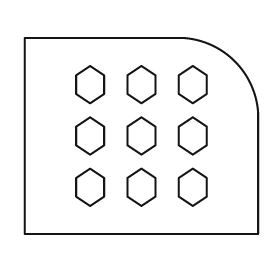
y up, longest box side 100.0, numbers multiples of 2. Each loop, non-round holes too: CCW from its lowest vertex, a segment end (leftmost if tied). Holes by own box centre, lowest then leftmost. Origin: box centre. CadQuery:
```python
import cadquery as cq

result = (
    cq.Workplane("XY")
    .moveTo(-50.0, -42.0)
    .lineTo(50.0, -42.0)
    .lineTo(50.0, 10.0)
    .threePointArc((40.0, 32.0), (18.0, 42.0))
    .lineTo(-50.0, 42.0)
    .close()
    .moveTo(-22.0, -30.0)
    .lineTo(-16.0, -26.0)
    .lineTo(-16.0, -18.0)
    .lineTo(-22.0, -14.0)
    .lineTo(-28.0, -18.0)
    .lineTo(-28.0, -26.0)
    .close()
    .moveTo(0.0, -30.0)
    .lineTo(6.0, -26.0)
    .lineTo(6.0, -18.0)
    .lineTo(0.0, -14.0)
    .lineTo(-6.0, -18.0)
    .lineTo(-6.0, -26.0)
    .close()
    .moveTo(22.0, -30.0)
    .lineTo(28.0, -26.0)
    .lineTo(28.0, -18.0)
    .lineTo(22.0, -14.0)
    .lineTo(16.0, -18.0)
    .lineTo(16.0, -26.0)
    .close()
    .moveTo(-22.0, -8.0)
    .lineTo(-16.0, -4.0)
    .lineTo(-16.0, 4.0)
    .lineTo(-22.0, 8.0)
    .lineTo(-28.0, 4.0)
    .lineTo(-28.0, -4.0)
    .close()
    .moveTo(0.0, -8.0)
    .lineTo(6.0, -4.0)
    .lineTo(6.0, 4.0)
    .lineTo(0.0, 8.0)
    .lineTo(-6.0, 4.0)
    .lineTo(-6.0, -4.0)
    .close()
    .moveTo(22.0, -8.0)
    .lineTo(28.0, -4.0)
    .lineTo(28.0, 4.0)
    .lineTo(22.0, 8.0)
    .lineTo(16.0, 4.0)
    .lineTo(16.0, -4.0)
    .close()
    .moveTo(-22.0, 14.0)
    .lineTo(-16.0, 18.0)
    .lineTo(-16.0, 26.0)
    .lineTo(-22.0, 30.0)
    .lineTo(-28.0, 26.0)
    .lineTo(-28.0, 18.0)
    .close()
    .moveTo(0.0, 14.0)
    .lineTo(6.0, 18.0)
    .lineTo(6.0, 26.0)
    .lineTo(0.0, 30.0)
    .lineTo(-6.0, 26.0)
    .lineTo(-6.0, 18.0)
    .close()
    .moveTo(22.0, 14.0)
    .lineTo(28.0, 18.0)
    .lineTo(28.0, 26.0)
    .lineTo(22.0, 30.0)
    .lineTo(16.0, 26.0)
    .lineTo(16.0, 18.0)
    .close()
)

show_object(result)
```